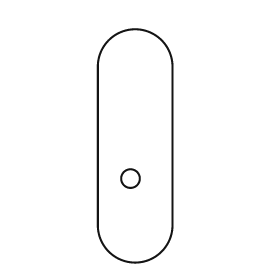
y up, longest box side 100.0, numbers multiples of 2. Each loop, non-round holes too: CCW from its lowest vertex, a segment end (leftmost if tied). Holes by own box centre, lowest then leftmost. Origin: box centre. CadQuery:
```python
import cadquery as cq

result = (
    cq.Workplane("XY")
    .moveTo(-16.0, -34.0)
    .threePointArc((0.0, -50.0), (16.0, -34.0))
    .lineTo(16.0, 34.0)
    .threePointArc((0.0, 50.0), (-16.0, 34.0))
    .close()
    .moveTo(-2.0, -14.0)
    .circle(4.0)
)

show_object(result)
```